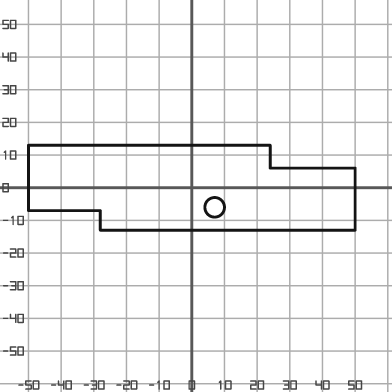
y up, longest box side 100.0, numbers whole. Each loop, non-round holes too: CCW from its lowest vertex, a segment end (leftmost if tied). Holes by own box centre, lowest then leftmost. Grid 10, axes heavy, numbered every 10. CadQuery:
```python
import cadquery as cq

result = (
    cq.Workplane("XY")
    .moveTo(-28.0, -13.0)
    .lineTo(50.0, -13.0)
    .lineTo(50.0, 6.0)
    .lineTo(24.0, 6.0)
    .lineTo(24.0, 13.0)
    .lineTo(-50.0, 13.0)
    .lineTo(-50.0, -7.0)
    .lineTo(-28.0, -7.0)
    .close()
    .moveTo(7.0, -6.0)
    .circle(3.0)
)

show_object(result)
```